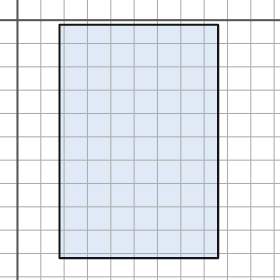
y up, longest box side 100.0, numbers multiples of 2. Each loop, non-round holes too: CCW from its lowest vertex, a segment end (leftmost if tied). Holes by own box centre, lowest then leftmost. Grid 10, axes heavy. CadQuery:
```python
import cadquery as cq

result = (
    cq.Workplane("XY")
    .moveTo(18.0, -102.0)
    .lineTo(86.0, -102.0)
    .lineTo(86.0, -2.0)
    .lineTo(18.0, -2.0)
    .close()
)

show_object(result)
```